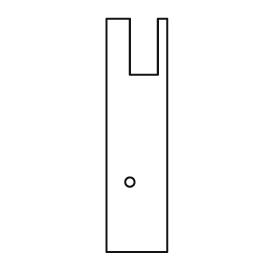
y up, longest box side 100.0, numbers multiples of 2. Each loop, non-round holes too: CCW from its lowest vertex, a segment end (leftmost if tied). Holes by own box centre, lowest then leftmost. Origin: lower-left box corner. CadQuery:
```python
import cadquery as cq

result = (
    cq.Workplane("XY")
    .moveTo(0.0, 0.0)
    .lineTo(26.0, 0.0)
    .lineTo(26.0, 100.0)
    .lineTo(22.0, 100.0)
    .lineTo(22.0, 76.0)
    .lineTo(10.0, 76.0)
    .lineTo(10.0, 100.0)
    .lineTo(0.0, 100.0)
    .close()
    .moveTo(10.0, 30.0)
    .circle(2.0)
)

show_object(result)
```